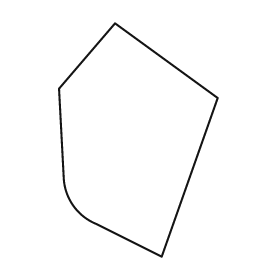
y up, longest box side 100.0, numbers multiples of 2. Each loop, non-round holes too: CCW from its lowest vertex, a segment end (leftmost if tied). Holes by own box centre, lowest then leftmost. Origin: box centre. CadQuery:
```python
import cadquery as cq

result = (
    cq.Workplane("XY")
    .moveTo(10.0, -50.0)
    .lineTo(34.0, 18.0)
    .lineTo(-10.0, 50.0)
    .lineTo(-34.0, 22.0)
    .lineTo(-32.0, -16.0)
    .threePointArc((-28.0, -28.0), (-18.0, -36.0))
    .close()
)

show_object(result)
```